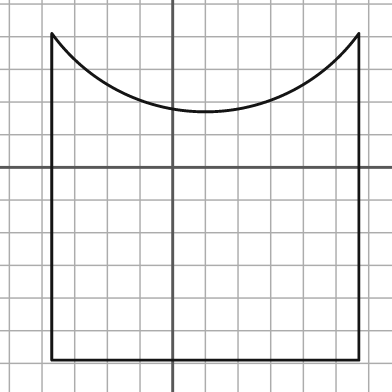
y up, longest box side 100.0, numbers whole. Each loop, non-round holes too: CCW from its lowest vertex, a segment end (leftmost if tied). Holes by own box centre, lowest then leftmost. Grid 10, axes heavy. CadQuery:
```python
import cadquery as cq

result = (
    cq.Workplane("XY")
    .moveTo(-37.0, -59.0)
    .lineTo(57.0, -59.0)
    .lineTo(57.0, 41.0)
    .threePointArc((10.0, 17.0), (-37.0, 41.0))
    .close()
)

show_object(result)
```